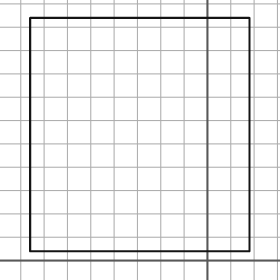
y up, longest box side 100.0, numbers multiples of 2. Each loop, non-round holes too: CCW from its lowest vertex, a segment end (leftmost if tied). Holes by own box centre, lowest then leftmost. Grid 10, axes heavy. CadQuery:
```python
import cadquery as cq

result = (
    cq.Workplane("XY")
    .moveTo(-76.0, 4.0)
    .lineTo(18.0, 4.0)
    .lineTo(18.0, 104.0)
    .lineTo(-76.0, 104.0)
    .close()
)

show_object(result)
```